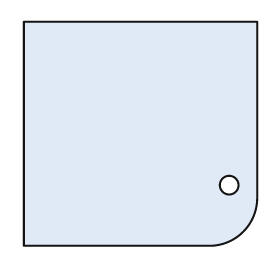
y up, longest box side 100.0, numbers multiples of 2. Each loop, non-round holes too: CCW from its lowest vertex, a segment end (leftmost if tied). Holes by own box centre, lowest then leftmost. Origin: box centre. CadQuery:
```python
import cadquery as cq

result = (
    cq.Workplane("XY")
    .moveTo(-50.0, -48.0)
    .lineTo(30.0, -48.0)
    .threePointArc((44.0, -42.0), (50.0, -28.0))
    .lineTo(50.0, 48.0)
    .lineTo(-50.0, 48.0)
    .close()
    .moveTo(38.0, -22.0)
    .circle(4.0)
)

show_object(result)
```